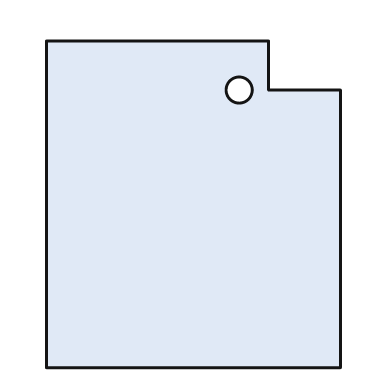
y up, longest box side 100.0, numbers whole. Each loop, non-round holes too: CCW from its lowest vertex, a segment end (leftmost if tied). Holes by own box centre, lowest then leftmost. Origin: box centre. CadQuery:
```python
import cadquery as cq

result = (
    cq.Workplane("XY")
    .moveTo(-45.0, -50.0)
    .lineTo(45.0, -50.0)
    .lineTo(45.0, 35.0)
    .lineTo(23.0, 35.0)
    .lineTo(23.0, 50.0)
    .lineTo(-45.0, 50.0)
    .close()
    .moveTo(14.0, 35.0)
    .circle(4.0)
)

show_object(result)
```